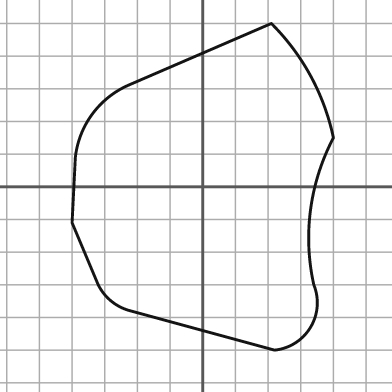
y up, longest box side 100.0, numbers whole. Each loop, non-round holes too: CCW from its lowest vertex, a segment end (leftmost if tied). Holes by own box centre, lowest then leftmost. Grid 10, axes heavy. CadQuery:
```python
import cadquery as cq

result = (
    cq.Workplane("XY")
    .moveTo(22.0, -50.0)
    .threePointArc((33.0, -43.0), (34.0, -30.0))
    .threePointArc((33.0, -7.0), (40.0, 15.0))
    .threePointArc((33.0, 34.0), (21.0, 50.0))
    .lineTo(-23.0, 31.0)
    .threePointArc((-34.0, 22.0), (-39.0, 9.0))
    .lineTo(-40.0, -11.0)
    .lineTo(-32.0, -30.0)
    .threePointArc((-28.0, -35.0), (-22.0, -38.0))
    .close()
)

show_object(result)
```